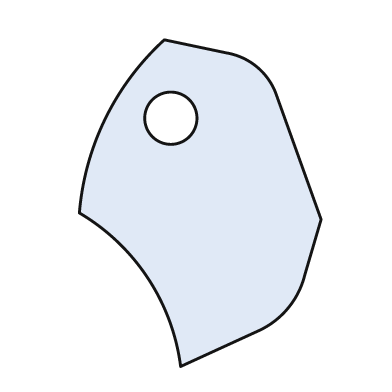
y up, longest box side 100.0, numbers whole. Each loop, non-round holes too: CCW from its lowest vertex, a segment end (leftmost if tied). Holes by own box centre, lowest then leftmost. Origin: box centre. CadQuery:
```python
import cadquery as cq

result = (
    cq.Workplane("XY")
    .moveTo(-6.0, -50.0)
    .lineTo(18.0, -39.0)
    .threePointArc((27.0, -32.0), (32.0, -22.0))
    .lineTo(37.0, -5.0)
    .lineTo(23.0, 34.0)
    .threePointArc((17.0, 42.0), (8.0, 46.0))
    .lineTo(-11.0, 50.0)
    .threePointArc((-29.0, 26.0), (-37.0, -3.0))
    .threePointArc((-16.0, -23.0), (-6.0, -50.0))
    .close()
    .moveTo(-9.0, 26.0)
    .circle(8.0)
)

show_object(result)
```